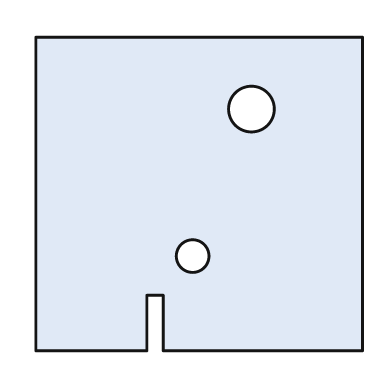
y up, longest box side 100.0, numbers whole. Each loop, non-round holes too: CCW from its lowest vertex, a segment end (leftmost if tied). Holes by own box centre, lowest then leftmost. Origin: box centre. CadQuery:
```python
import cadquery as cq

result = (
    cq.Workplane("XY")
    .moveTo(-50.0, -48.0)
    .lineTo(-16.0, -48.0)
    .lineTo(-16.0, -31.0)
    .lineTo(-11.0, -31.0)
    .lineTo(-11.0, -48.0)
    .lineTo(50.0, -48.0)
    .lineTo(50.0, 48.0)
    .lineTo(-50.0, 48.0)
    .close()
    .moveTo(-2.0, -19.0)
    .circle(5.0)
    .moveTo(16.0, 26.0)
    .circle(7.0)
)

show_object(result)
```